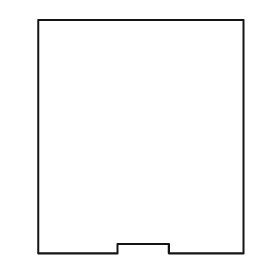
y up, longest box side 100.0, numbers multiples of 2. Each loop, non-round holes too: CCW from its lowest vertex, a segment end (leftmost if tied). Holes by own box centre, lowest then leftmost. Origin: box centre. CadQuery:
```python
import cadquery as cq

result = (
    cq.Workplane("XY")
    .moveTo(-44.0, -50.0)
    .lineTo(-10.0, -50.0)
    .lineTo(-10.0, -46.0)
    .lineTo(12.0, -46.0)
    .lineTo(12.0, -50.0)
    .lineTo(44.0, -50.0)
    .lineTo(44.0, 50.0)
    .lineTo(-44.0, 50.0)
    .close()
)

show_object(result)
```